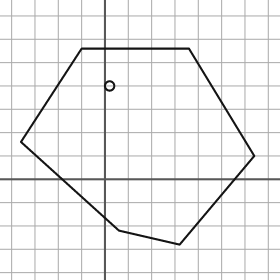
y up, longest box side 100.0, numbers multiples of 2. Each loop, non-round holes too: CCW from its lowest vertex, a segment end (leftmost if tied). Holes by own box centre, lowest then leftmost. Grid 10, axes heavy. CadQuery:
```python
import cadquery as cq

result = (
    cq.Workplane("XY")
    .moveTo(32.0, -28.0)
    .lineTo(64.0, 10.0)
    .lineTo(36.0, 56.0)
    .lineTo(-10.0, 56.0)
    .lineTo(-36.0, 16.0)
    .lineTo(6.0, -22.0)
    .close()
    .moveTo(2.0, 40.0)
    .circle(2.0)
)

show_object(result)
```